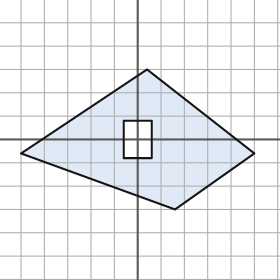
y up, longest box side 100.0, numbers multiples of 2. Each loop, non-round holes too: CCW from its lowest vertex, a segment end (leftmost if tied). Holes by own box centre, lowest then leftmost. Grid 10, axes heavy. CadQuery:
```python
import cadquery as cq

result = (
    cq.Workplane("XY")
    .moveTo(16.0, -30.0)
    .lineTo(50.0, -6.0)
    .lineTo(4.0, 30.0)
    .lineTo(-50.0, -6.0)
    .close()
    .moveTo(-6.0, -8.0)
    .lineTo(6.0, -8.0)
    .lineTo(6.0, 8.0)
    .lineTo(-6.0, 8.0)
    .close()
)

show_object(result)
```